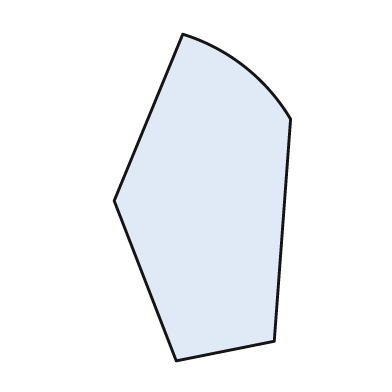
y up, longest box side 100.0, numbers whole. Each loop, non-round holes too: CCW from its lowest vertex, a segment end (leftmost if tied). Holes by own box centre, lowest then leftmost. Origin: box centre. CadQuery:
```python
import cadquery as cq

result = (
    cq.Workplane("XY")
    .moveTo(-8.0, -50.0)
    .lineTo(22.0, -44.0)
    .lineTo(27.0, 24.0)
    .threePointArc((13.0, 40.0), (-6.0, 50.0))
    .lineTo(-27.0, -1.0)
    .close()
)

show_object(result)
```